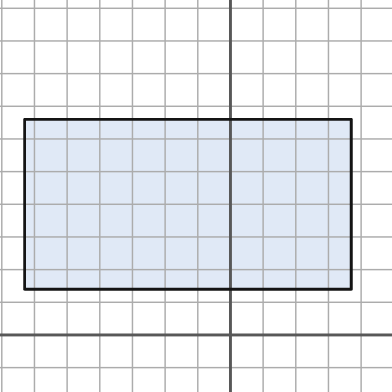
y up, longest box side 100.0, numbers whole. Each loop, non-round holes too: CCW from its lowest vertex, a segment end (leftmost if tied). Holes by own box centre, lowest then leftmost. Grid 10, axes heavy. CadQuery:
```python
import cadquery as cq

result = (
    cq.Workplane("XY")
    .moveTo(-63.0, 14.0)
    .lineTo(37.0, 14.0)
    .lineTo(37.0, 66.0)
    .lineTo(-63.0, 66.0)
    .close()
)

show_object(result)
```